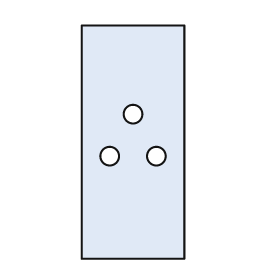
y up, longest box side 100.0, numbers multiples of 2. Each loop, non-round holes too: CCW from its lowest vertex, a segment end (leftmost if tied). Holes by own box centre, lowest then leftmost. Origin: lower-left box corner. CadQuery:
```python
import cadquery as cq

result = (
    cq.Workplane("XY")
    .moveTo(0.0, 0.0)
    .lineTo(44.0, 0.0)
    .lineTo(44.0, 100.0)
    .lineTo(0.0, 100.0)
    .close()
    .moveTo(12.0, 44.0)
    .circle(4.0)
    .moveTo(32.0, 44.0)
    .circle(4.0)
    .moveTo(22.0, 62.0)
    .circle(4.0)
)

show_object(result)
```